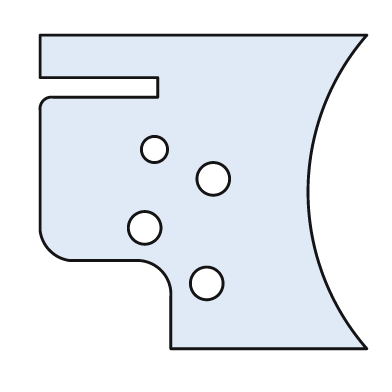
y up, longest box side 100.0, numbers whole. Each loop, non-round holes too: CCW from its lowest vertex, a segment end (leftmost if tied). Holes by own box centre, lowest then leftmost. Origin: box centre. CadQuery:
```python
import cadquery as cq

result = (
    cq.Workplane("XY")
    .moveTo(-10.0, -48.0)
    .lineTo(50.0, -48.0)
    .threePointArc((32.0, 0.0), (50.0, 48.0))
    .lineTo(-50.0, 48.0)
    .lineTo(-50.0, 35.0)
    .lineTo(-14.0, 35.0)
    .lineTo(-14.0, 29.0)
    .lineTo(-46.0, 29.0)
    .threePointArc((-49.0, 28.0), (-50.0, 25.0))
    .lineTo(-50.0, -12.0)
    .threePointArc((-47.0, -18.0), (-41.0, -21.0))
    .lineTo(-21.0, -21.0)
    .threePointArc((-13.0, -24.0), (-10.0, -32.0))
    .close()
    .moveTo(1.0, -28.0)
    .circle(5.0)
    .moveTo(-18.0, -11.0)
    .circle(5.0)
    .moveTo(3.0, 4.0)
    .circle(5.0)
    .moveTo(-15.0, 13.0)
    .circle(4.0)
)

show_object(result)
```